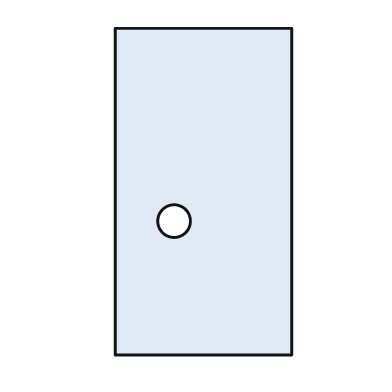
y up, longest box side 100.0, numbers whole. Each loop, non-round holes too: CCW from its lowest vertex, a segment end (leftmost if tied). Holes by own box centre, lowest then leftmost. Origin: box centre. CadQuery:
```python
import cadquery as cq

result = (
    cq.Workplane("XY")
    .moveTo(-27.0, -50.0)
    .lineTo(27.0, -50.0)
    .lineTo(27.0, 50.0)
    .lineTo(-27.0, 50.0)
    .close()
    .moveTo(-9.0, -9.0)
    .circle(5.0)
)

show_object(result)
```